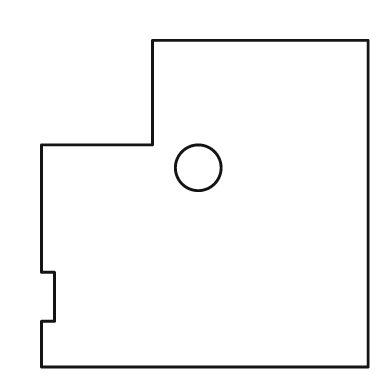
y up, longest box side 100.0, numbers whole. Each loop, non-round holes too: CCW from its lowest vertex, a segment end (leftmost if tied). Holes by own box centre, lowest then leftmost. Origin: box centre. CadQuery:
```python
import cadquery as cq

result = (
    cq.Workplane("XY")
    .moveTo(-50.0, -50.0)
    .lineTo(50.0, -50.0)
    .lineTo(50.0, 50.0)
    .lineTo(-16.0, 50.0)
    .lineTo(-16.0, 18.0)
    .lineTo(-50.0, 18.0)
    .lineTo(-50.0, -21.0)
    .lineTo(-46.0, -21.0)
    .lineTo(-46.0, -36.0)
    .lineTo(-50.0, -36.0)
    .close()
    .moveTo(-2.0, 11.0)
    .circle(7.0)
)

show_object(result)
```